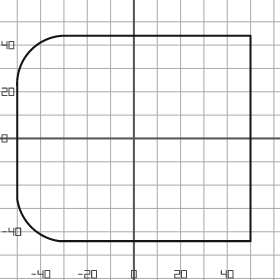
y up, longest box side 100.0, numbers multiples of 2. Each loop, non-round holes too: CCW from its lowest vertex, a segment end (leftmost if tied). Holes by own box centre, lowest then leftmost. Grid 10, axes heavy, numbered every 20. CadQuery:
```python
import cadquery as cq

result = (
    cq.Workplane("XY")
    .moveTo(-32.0, -44.0)
    .lineTo(50.0, -44.0)
    .lineTo(50.0, 44.0)
    .lineTo(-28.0, 44.0)
    .threePointArc((-44.0, 38.0), (-50.0, 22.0))
    .lineTo(-50.0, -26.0)
    .threePointArc((-44.0, -38.0), (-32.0, -44.0))
    .close()
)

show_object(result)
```